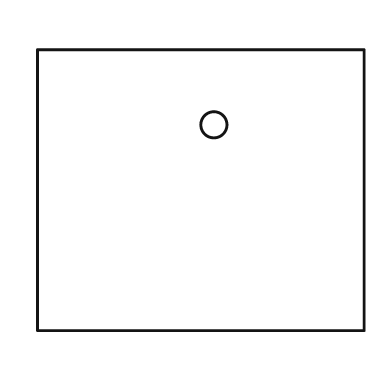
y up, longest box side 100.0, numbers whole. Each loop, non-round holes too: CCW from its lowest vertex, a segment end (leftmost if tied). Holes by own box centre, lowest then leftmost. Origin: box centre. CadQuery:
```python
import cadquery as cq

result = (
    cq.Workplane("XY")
    .moveTo(-50.0, -43.0)
    .lineTo(50.0, -43.0)
    .lineTo(50.0, 43.0)
    .lineTo(-50.0, 43.0)
    .close()
    .moveTo(4.0, 20.0)
    .circle(4.0)
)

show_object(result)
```